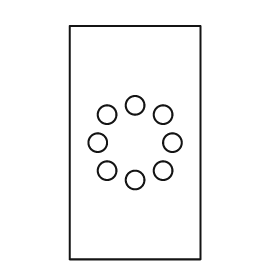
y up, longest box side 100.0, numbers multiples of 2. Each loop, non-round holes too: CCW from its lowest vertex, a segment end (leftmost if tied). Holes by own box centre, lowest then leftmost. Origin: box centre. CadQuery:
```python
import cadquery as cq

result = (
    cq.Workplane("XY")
    .moveTo(-28.0, -50.0)
    .lineTo(28.0, -50.0)
    .lineTo(28.0, 50.0)
    .lineTo(-28.0, 50.0)
    .close()
    .moveTo(0.0, -16.0)
    .circle(4.0)
    .moveTo(-12.0, -12.0)
    .circle(4.0)
    .moveTo(12.0, -12.0)
    .circle(4.0)
    .moveTo(-16.0, 0.0)
    .circle(4.0)
    .moveTo(16.0, 0.0)
    .circle(4.0)
    .moveTo(-12.0, 12.0)
    .circle(4.0)
    .moveTo(12.0, 12.0)
    .circle(4.0)
    .moveTo(0.0, 16.0)
    .circle(4.0)
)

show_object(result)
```